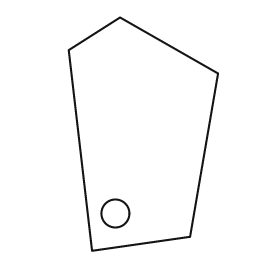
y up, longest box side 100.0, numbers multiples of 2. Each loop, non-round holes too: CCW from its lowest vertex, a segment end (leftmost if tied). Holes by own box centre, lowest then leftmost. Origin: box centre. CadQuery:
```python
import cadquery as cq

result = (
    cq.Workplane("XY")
    .moveTo(-22.0, -50.0)
    .lineTo(20.0, -44.0)
    .lineTo(32.0, 26.0)
    .lineTo(-10.0, 50.0)
    .lineTo(-32.0, 36.0)
    .close()
    .moveTo(-12.0, -34.0)
    .circle(6.0)
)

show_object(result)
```